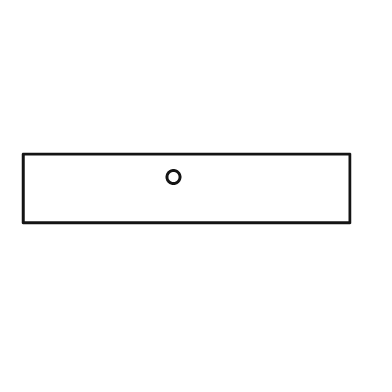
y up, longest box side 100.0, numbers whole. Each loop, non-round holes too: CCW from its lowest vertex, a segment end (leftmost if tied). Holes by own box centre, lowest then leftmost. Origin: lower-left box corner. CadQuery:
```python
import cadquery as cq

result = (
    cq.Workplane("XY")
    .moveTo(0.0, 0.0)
    .lineTo(100.0, 0.0)
    .lineTo(100.0, 21.0)
    .lineTo(0.0, 21.0)
    .close()
    .moveTo(46.0, 14.0)
    .circle(2.0)
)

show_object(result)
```